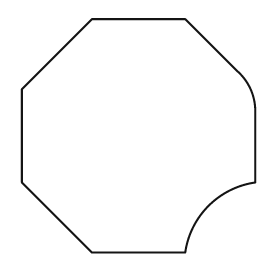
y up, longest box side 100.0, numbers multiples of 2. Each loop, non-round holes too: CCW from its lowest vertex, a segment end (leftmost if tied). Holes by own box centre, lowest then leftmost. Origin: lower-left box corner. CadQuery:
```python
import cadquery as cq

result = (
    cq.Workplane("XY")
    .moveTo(30.0, 0.0)
    .lineTo(70.0, 0.0)
    .threePointArc((80.0, 20.0), (100.0, 30.0))
    .lineTo(100.0, 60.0)
    .threePointArc((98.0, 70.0), (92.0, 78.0))
    .lineTo(70.0, 100.0)
    .lineTo(30.0, 100.0)
    .lineTo(0.0, 70.0)
    .lineTo(0.0, 30.0)
    .close()
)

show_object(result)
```